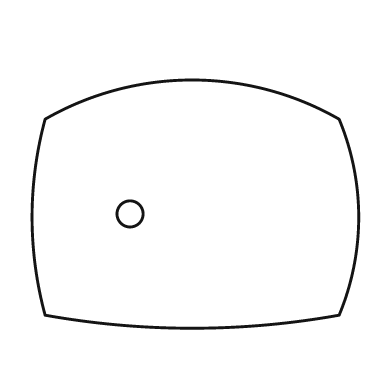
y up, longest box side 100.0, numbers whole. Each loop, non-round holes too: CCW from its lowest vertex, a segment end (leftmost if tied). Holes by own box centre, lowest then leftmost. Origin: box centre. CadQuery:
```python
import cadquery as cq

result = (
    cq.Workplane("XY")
    .moveTo(-46.0, -34.0)
    .threePointArc((-1.0, -38.0), (44.0, -34.0))
    .threePointArc((50.0, -4.0), (44.0, 26.0))
    .threePointArc((-1.0, 38.0), (-46.0, 26.0))
    .threePointArc((-50.0, -4.0), (-46.0, -34.0))
    .close()
    .moveTo(-20.0, -3.0)
    .circle(4.0)
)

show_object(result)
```